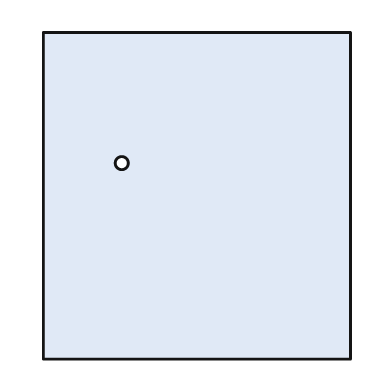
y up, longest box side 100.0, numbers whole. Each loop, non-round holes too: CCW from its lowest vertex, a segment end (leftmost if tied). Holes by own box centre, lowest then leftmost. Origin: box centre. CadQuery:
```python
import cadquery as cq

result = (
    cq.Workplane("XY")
    .moveTo(-47.0, -50.0)
    .lineTo(47.0, -50.0)
    .lineTo(47.0, 50.0)
    .lineTo(-47.0, 50.0)
    .close()
    .moveTo(-23.0, 10.0)
    .circle(2.0)
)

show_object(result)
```